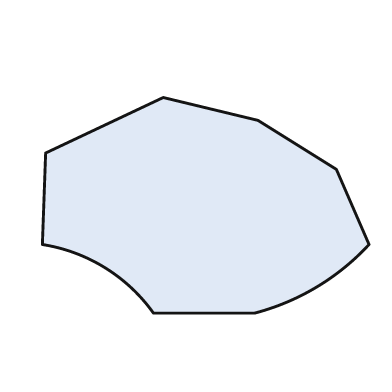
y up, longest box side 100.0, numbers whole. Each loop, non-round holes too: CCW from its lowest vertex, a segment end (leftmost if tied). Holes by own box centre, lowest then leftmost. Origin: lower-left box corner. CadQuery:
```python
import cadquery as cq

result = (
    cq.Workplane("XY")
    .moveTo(34.0, 0.0)
    .lineTo(65.0, 0.0)
    .threePointArc((84.0, 8.0), (100.0, 21.0))
    .lineTo(90.0, 44.0)
    .lineTo(66.0, 59.0)
    .lineTo(37.0, 66.0)
    .lineTo(1.0, 49.0)
    .lineTo(0.0, 21.0)
    .threePointArc((19.0, 14.0), (34.0, 0.0))
    .close()
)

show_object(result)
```